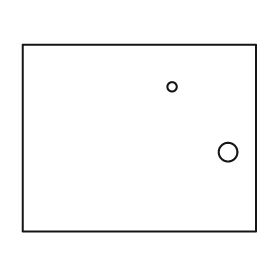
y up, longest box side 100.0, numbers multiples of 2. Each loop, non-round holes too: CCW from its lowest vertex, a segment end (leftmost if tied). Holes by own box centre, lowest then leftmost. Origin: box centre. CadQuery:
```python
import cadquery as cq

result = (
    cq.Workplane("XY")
    .moveTo(-50.0, -40.0)
    .lineTo(50.0, -40.0)
    .lineTo(50.0, 40.0)
    .lineTo(-50.0, 40.0)
    .close()
    .moveTo(38.0, -6.0)
    .circle(4.0)
    .moveTo(14.0, 22.0)
    .circle(2.0)
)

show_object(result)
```